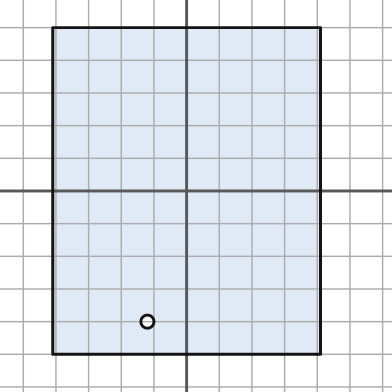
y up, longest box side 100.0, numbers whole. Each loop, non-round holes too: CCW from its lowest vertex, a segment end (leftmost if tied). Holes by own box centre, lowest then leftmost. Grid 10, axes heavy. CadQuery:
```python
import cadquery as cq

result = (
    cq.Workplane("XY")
    .moveTo(-41.0, -50.0)
    .lineTo(41.0, -50.0)
    .lineTo(41.0, 50.0)
    .lineTo(-41.0, 50.0)
    .close()
    .moveTo(-12.0, -40.0)
    .circle(2.0)
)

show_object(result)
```